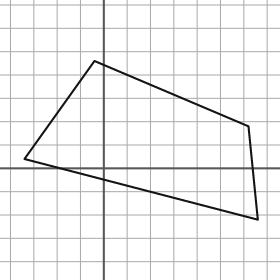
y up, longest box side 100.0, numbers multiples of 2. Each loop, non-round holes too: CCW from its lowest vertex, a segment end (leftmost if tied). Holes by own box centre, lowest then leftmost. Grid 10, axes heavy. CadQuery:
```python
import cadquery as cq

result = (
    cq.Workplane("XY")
    .moveTo(66.0, -22.0)
    .lineTo(62.0, 18.0)
    .lineTo(-4.0, 46.0)
    .lineTo(-34.0, 4.0)
    .close()
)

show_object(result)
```